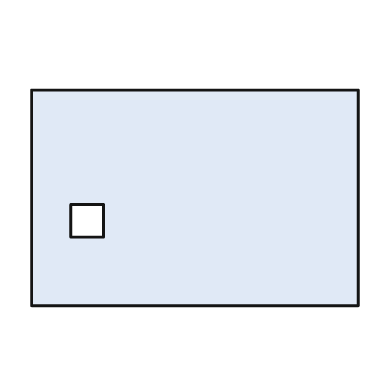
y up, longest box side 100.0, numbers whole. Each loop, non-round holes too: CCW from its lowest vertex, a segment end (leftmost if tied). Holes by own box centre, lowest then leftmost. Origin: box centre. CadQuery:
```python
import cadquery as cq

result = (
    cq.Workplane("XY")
    .moveTo(-50.0, -33.0)
    .lineTo(50.0, -33.0)
    .lineTo(50.0, 33.0)
    .lineTo(-50.0, 33.0)
    .close()
    .moveTo(-38.0, -12.0)
    .lineTo(-28.0, -12.0)
    .lineTo(-28.0, -2.0)
    .lineTo(-38.0, -2.0)
    .close()
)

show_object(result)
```